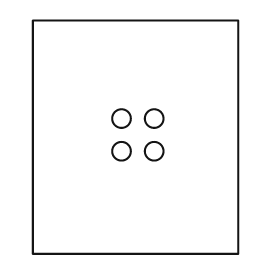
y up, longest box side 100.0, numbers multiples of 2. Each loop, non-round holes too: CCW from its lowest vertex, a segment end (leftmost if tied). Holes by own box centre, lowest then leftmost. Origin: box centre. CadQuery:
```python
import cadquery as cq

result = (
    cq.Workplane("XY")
    .moveTo(-44.0, -50.0)
    .lineTo(44.0, -50.0)
    .lineTo(44.0, 50.0)
    .lineTo(-44.0, 50.0)
    .close()
    .moveTo(-6.0, -6.0)
    .circle(4.0)
    .moveTo(8.0, -6.0)
    .circle(4.0)
    .moveTo(-6.0, 8.0)
    .circle(4.0)
    .moveTo(8.0, 8.0)
    .circle(4.0)
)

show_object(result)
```